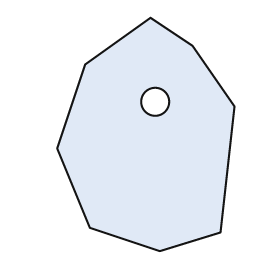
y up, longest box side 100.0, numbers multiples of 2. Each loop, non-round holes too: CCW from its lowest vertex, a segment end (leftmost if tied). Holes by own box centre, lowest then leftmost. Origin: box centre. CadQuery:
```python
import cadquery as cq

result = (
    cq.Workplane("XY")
    .moveTo(6.0, -50.0)
    .lineTo(32.0, -42.0)
    .lineTo(38.0, 12.0)
    .lineTo(20.0, 38.0)
    .lineTo(2.0, 50.0)
    .lineTo(-26.0, 30.0)
    .lineTo(-38.0, -6.0)
    .lineTo(-24.0, -40.0)
    .close()
    .moveTo(4.0, 14.0)
    .circle(6.0)
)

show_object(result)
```